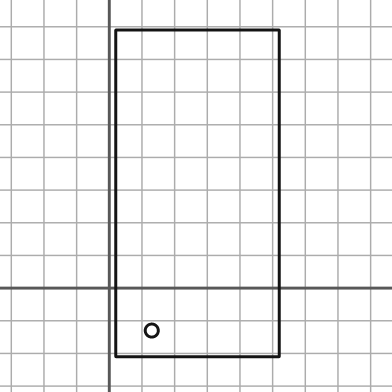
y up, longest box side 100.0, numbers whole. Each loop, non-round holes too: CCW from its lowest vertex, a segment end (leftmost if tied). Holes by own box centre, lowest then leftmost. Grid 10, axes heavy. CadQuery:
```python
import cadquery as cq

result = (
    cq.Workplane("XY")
    .moveTo(2.0, -21.0)
    .lineTo(52.0, -21.0)
    .lineTo(52.0, 79.0)
    .lineTo(2.0, 79.0)
    .close()
    .moveTo(13.0, -13.0)
    .circle(2.0)
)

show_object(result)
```